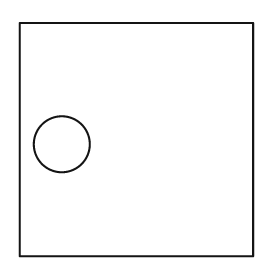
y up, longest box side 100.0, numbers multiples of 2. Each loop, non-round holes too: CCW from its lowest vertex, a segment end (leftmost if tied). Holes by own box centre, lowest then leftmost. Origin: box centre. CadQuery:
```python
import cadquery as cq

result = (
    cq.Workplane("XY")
    .moveTo(-50.0, -50.0)
    .lineTo(50.0, -50.0)
    .lineTo(50.0, 50.0)
    .lineTo(-50.0, 50.0)
    .close()
    .moveTo(-32.0, -2.0)
    .circle(12.0)
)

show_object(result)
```